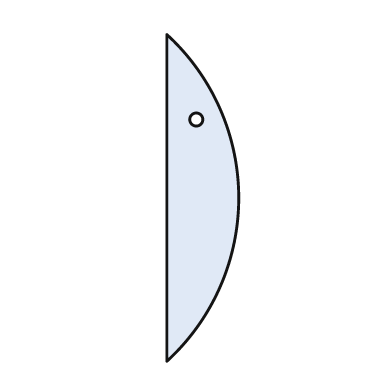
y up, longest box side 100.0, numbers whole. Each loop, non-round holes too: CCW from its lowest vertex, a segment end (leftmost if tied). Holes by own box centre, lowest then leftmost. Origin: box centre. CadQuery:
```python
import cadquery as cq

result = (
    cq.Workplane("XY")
    .moveTo(-11.0, -50.0)
    .threePointArc((11.0, 0.0), (-11.0, 50.0))
    .close()
    .moveTo(-2.0, 24.0)
    .circle(2.0)
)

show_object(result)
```